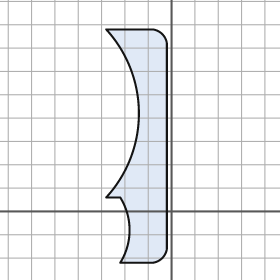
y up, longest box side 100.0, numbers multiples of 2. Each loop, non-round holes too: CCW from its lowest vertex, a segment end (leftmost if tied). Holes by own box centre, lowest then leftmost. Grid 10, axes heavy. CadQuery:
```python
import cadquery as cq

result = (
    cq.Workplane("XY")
    .moveTo(-22.0, -22.0)
    .lineTo(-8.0, -22.0)
    .threePointArc((-4.0, -20.0), (-2.0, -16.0))
    .lineTo(-2.0, 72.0)
    .threePointArc((-4.0, 76.0), (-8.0, 78.0))
    .lineTo(-28.0, 78.0)
    .threePointArc((-14.0, 42.0), (-28.0, 6.0))
    .lineTo(-22.0, 6.0)
    .threePointArc((-18.0, -8.0), (-22.0, -22.0))
    .close()
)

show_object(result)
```